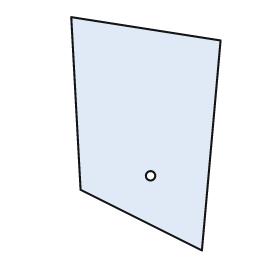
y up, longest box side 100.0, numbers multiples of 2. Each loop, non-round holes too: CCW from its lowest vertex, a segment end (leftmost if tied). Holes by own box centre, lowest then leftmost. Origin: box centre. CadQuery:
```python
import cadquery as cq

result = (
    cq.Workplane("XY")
    .moveTo(24.0, -50.0)
    .lineTo(32.0, 40.0)
    .lineTo(-32.0, 50.0)
    .lineTo(-28.0, -24.0)
    .close()
    .moveTo(2.0, -18.0)
    .circle(2.0)
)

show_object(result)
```